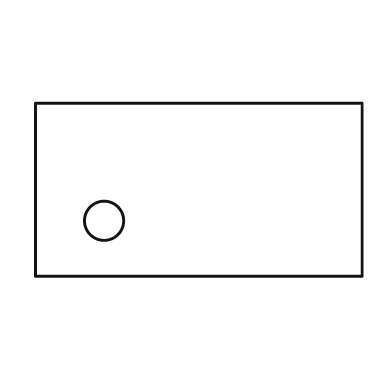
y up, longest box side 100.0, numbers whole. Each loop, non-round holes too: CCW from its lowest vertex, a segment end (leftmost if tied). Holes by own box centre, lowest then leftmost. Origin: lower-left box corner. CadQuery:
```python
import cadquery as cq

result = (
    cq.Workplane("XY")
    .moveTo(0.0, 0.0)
    .lineTo(100.0, 0.0)
    .lineTo(100.0, 53.0)
    .lineTo(0.0, 53.0)
    .close()
    .moveTo(21.0, 17.0)
    .circle(6.0)
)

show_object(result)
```